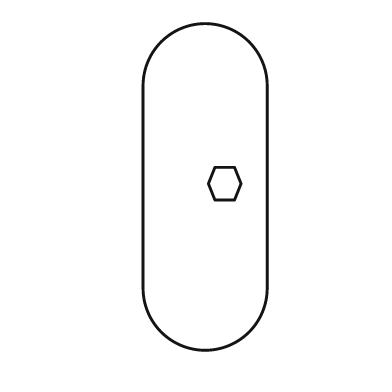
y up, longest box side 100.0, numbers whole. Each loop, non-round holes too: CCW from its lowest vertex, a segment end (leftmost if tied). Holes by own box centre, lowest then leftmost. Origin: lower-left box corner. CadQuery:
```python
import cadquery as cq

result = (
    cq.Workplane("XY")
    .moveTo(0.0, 19.0)
    .threePointArc((19.0, 0.0), (38.0, 19.0))
    .lineTo(38.0, 81.0)
    .threePointArc((19.0, 100.0), (0.0, 81.0))
    .close()
    .moveTo(22.0, 46.0)
    .lineTo(28.0, 46.0)
    .lineTo(30.0, 51.0)
    .lineTo(28.0, 56.0)
    .lineTo(22.0, 56.0)
    .lineTo(20.0, 51.0)
    .close()
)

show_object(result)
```